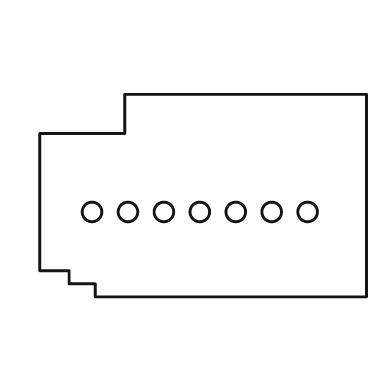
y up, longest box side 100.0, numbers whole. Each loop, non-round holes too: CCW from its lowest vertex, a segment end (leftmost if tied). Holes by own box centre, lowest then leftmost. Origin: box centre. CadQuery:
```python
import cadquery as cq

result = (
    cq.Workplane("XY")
    .moveTo(-33.0, -31.0)
    .lineTo(50.0, -31.0)
    .lineTo(50.0, 31.0)
    .lineTo(-24.0, 31.0)
    .lineTo(-24.0, 19.0)
    .lineTo(-50.0, 19.0)
    .lineTo(-50.0, -23.0)
    .lineTo(-41.0, -23.0)
    .lineTo(-41.0, -27.0)
    .lineTo(-33.0, -27.0)
    .close()
    .moveTo(-34.0, -5.0)
    .circle(3.0)
    .moveTo(-23.0, -5.0)
    .circle(3.0)
    .moveTo(-12.0, -5.0)
    .circle(3.0)
    .moveTo(-1.0, -5.0)
    .circle(3.0)
    .moveTo(10.0, -5.0)
    .circle(3.0)
    .moveTo(21.0, -5.0)
    .circle(3.0)
    .moveTo(32.0, -5.0)
    .circle(3.0)
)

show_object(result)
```